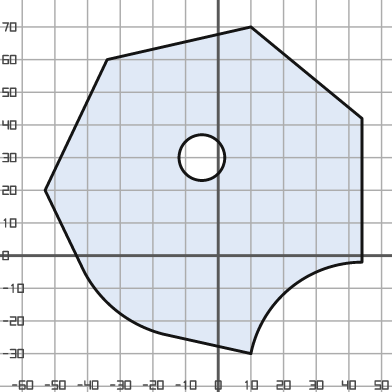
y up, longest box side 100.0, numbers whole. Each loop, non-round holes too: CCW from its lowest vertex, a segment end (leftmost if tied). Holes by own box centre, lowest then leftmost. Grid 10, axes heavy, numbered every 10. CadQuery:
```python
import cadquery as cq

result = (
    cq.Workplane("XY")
    .moveTo(10.0, -30.0)
    .threePointArc((22.0, -10.0), (44.0, -2.0))
    .lineTo(44.0, 42.0)
    .lineTo(10.0, 70.0)
    .lineTo(-34.0, 60.0)
    .lineTo(-53.0, 20.0)
    .lineTo(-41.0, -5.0)
    .threePointArc((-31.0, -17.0), (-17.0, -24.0))
    .close()
    .moveTo(-5.0, 30.0)
    .circle(7.0)
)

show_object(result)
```